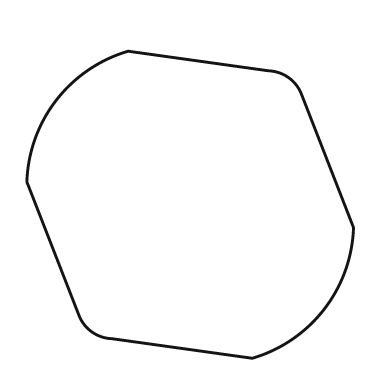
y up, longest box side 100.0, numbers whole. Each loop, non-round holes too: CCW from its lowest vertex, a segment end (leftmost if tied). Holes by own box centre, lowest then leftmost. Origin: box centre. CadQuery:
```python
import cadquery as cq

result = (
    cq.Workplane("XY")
    .moveTo(19.0, -47.0)
    .threePointArc((41.0, -32.0), (50.0, -7.0))
    .lineTo(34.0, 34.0)
    .threePointArc((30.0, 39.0), (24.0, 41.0))
    .lineTo(-19.0, 47.0)
    .threePointArc((-41.0, 32.0), (-50.0, 7.0))
    .lineTo(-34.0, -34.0)
    .threePointArc((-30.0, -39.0), (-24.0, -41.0))
    .close()
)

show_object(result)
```